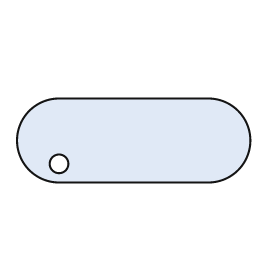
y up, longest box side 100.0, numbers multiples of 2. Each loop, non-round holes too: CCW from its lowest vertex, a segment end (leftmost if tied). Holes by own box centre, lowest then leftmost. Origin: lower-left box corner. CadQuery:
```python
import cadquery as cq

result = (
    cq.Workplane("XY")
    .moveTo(18.0, 0.0)
    .lineTo(82.0, 0.0)
    .threePointArc((100.0, 18.0), (82.0, 36.0))
    .lineTo(18.0, 36.0)
    .threePointArc((0.0, 18.0), (18.0, 0.0))
    .close()
    .moveTo(18.0, 8.0)
    .circle(4.0)
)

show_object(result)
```